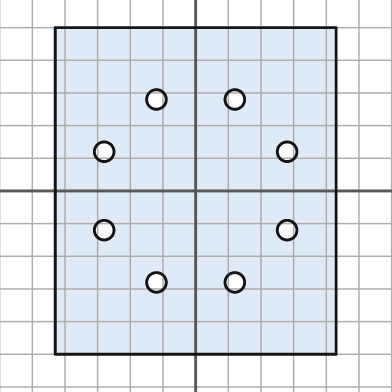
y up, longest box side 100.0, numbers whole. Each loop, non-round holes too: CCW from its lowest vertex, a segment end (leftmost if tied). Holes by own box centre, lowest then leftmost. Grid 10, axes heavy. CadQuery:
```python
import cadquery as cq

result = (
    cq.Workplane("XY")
    .moveTo(-43.0, -50.0)
    .lineTo(43.0, -50.0)
    .lineTo(43.0, 50.0)
    .lineTo(-43.0, 50.0)
    .close()
    .moveTo(-12.0, -28.0)
    .circle(3.0)
    .moveTo(12.0, -28.0)
    .circle(3.0)
    .moveTo(-28.0, -12.0)
    .circle(3.0)
    .moveTo(28.0, -12.0)
    .circle(3.0)
    .moveTo(-28.0, 12.0)
    .circle(3.0)
    .moveTo(28.0, 12.0)
    .circle(3.0)
    .moveTo(-12.0, 28.0)
    .circle(3.0)
    .moveTo(12.0, 28.0)
    .circle(3.0)
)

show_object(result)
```